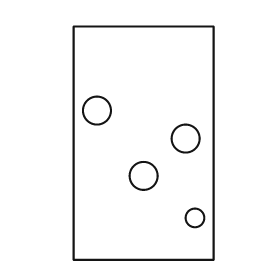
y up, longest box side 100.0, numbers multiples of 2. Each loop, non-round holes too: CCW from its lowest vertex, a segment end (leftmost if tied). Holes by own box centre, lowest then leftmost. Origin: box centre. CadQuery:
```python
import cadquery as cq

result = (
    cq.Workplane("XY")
    .moveTo(-30.0, -50.0)
    .lineTo(30.0, -50.0)
    .lineTo(30.0, 50.0)
    .lineTo(-30.0, 50.0)
    .close()
    .moveTo(22.0, -32.0)
    .circle(4.0)
    .moveTo(0.0, -14.0)
    .circle(6.0)
    .moveTo(18.0, 2.0)
    .circle(6.0)
    .moveTo(-20.0, 14.0)
    .circle(6.0)
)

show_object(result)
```